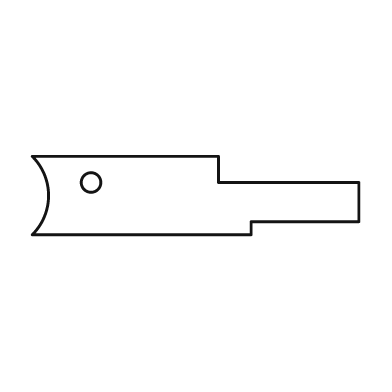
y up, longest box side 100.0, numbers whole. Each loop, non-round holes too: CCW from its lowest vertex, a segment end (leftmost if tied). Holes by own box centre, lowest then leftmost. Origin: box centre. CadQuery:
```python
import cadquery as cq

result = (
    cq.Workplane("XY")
    .moveTo(-50.0, -12.0)
    .lineTo(17.0, -12.0)
    .lineTo(17.0, -8.0)
    .lineTo(50.0, -8.0)
    .lineTo(50.0, 4.0)
    .lineTo(7.0, 4.0)
    .lineTo(7.0, 12.0)
    .lineTo(-50.0, 12.0)
    .threePointArc((-45.0, 0.0), (-50.0, -12.0))
    .close()
    .moveTo(-32.0, 4.0)
    .circle(3.0)
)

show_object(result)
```